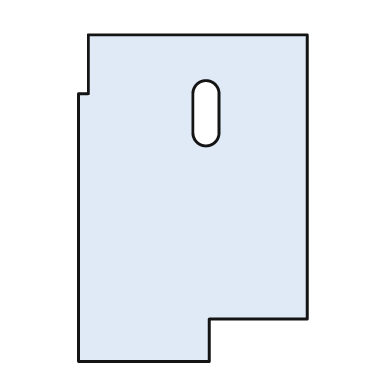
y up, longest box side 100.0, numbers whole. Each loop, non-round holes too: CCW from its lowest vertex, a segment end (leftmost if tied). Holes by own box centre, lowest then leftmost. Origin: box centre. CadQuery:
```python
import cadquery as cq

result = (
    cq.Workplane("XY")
    .moveTo(-35.0, -50.0)
    .lineTo(5.0, -50.0)
    .lineTo(5.0, -37.0)
    .lineTo(35.0, -37.0)
    .lineTo(35.0, 50.0)
    .lineTo(-32.0, 50.0)
    .lineTo(-32.0, 32.0)
    .lineTo(-35.0, 32.0)
    .close()
    .moveTo(0.0, 20.0)
    .threePointArc((4.0, 16.0), (8.0, 20.0))
    .lineTo(8.0, 32.0)
    .threePointArc((4.0, 36.0), (0.0, 32.0))
    .close()
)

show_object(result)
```